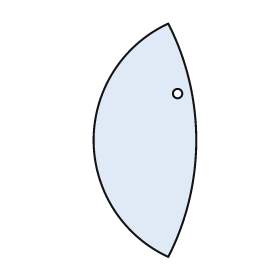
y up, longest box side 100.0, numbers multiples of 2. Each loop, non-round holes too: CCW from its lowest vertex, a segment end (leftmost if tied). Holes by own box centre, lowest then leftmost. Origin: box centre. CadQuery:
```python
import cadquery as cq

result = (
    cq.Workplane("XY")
    .moveTo(10.0, -50.0)
    .threePointArc((22.0, 0.0), (10.0, 50.0))
    .threePointArc((-22.0, 0.0), (10.0, -50.0))
    .close()
    .moveTo(14.0, 20.0)
    .circle(2.0)
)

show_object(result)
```